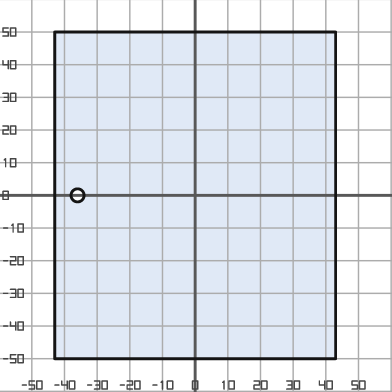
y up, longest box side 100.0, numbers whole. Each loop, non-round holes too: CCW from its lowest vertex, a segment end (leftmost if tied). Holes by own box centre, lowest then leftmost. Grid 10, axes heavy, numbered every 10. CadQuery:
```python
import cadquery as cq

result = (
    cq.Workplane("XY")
    .moveTo(-43.0, -50.0)
    .lineTo(43.0, -50.0)
    .lineTo(43.0, 50.0)
    .lineTo(-43.0, 50.0)
    .close()
    .moveTo(-36.0, 0.0)
    .circle(2.0)
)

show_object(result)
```